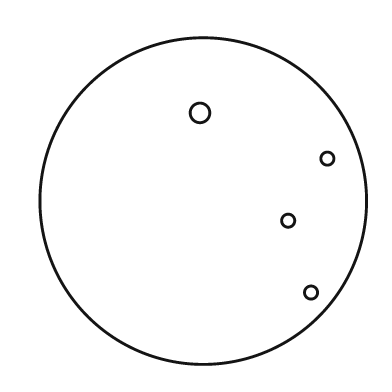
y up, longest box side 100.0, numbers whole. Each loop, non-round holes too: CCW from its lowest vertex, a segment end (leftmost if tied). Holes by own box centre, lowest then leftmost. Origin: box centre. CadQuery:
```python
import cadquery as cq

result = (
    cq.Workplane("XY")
    .moveTo(0.0, 0.0)
    .circle(50.0)
    .moveTo(33.0, -28.0)
    .circle(2.0)
    .moveTo(26.0, -6.0)
    .circle(2.0)
    .moveTo(38.0, 13.0)
    .circle(2.0)
    .moveTo(-1.0, 27.0)
    .circle(3.0)
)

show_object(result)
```